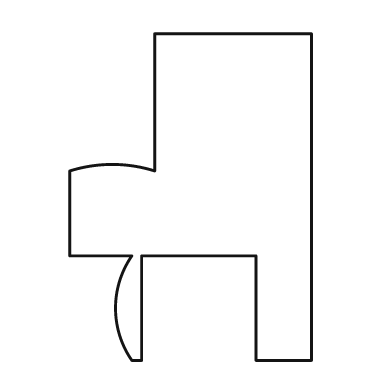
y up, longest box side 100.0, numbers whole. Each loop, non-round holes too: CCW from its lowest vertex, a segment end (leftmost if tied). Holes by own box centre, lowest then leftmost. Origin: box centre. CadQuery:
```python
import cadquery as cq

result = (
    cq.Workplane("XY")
    .moveTo(-18.0, -50.0)
    .lineTo(-15.0, -50.0)
    .lineTo(-15.0, -18.0)
    .lineTo(20.0, -18.0)
    .lineTo(20.0, -50.0)
    .lineTo(37.0, -50.0)
    .lineTo(37.0, 50.0)
    .lineTo(-11.0, 50.0)
    .lineTo(-11.0, 8.0)
    .threePointArc((-24.0, 10.0), (-37.0, 8.0))
    .lineTo(-37.0, -18.0)
    .lineTo(-18.0, -18.0)
    .threePointArc((-23.0, -34.0), (-18.0, -50.0))
    .close()
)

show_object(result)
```